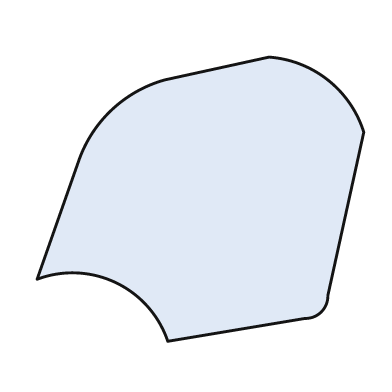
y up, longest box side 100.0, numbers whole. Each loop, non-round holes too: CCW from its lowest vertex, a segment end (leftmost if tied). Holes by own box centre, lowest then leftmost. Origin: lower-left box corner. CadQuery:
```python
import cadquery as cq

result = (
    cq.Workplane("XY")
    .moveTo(40.0, 0.0)
    .lineTo(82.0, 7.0)
    .threePointArc((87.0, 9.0), (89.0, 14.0))
    .lineTo(100.0, 64.0)
    .threePointArc((89.0, 80.0), (71.0, 87.0))
    .lineTo(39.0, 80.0)
    .threePointArc((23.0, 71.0), (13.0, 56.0))
    .lineTo(0.0, 19.0)
    .threePointArc((24.0, 18.0), (40.0, 0.0))
    .close()
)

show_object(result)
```